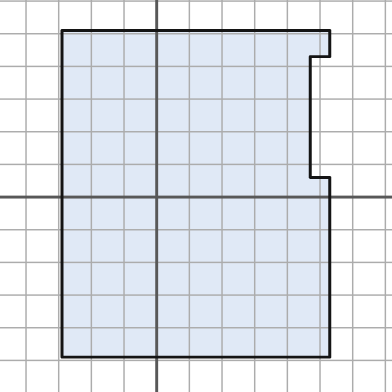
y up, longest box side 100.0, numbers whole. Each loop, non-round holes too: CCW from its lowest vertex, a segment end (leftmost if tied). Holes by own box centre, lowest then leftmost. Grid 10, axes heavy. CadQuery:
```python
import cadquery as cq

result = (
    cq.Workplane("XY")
    .moveTo(-29.0, -49.0)
    .lineTo(53.0, -49.0)
    .lineTo(53.0, 6.0)
    .lineTo(47.0, 6.0)
    .lineTo(47.0, 43.0)
    .lineTo(53.0, 43.0)
    .lineTo(53.0, 51.0)
    .lineTo(-29.0, 51.0)
    .close()
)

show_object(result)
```